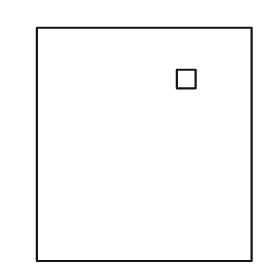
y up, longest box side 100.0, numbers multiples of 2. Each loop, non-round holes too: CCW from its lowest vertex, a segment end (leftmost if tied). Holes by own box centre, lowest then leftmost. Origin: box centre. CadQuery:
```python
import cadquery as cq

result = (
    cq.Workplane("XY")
    .moveTo(-46.0, -50.0)
    .lineTo(46.0, -50.0)
    .lineTo(46.0, 50.0)
    .lineTo(-46.0, 50.0)
    .close()
    .moveTo(14.0, 24.0)
    .lineTo(22.0, 24.0)
    .lineTo(22.0, 32.0)
    .lineTo(14.0, 32.0)
    .close()
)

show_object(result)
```